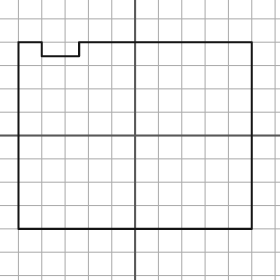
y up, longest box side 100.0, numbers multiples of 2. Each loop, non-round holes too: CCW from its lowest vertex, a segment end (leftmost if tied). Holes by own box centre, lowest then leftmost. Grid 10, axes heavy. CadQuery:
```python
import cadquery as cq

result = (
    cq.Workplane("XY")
    .moveTo(-50.0, -40.0)
    .lineTo(50.0, -40.0)
    .lineTo(50.0, 40.0)
    .lineTo(-24.0, 40.0)
    .lineTo(-24.0, 34.0)
    .lineTo(-40.0, 34.0)
    .lineTo(-40.0, 40.0)
    .lineTo(-50.0, 40.0)
    .close()
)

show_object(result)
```